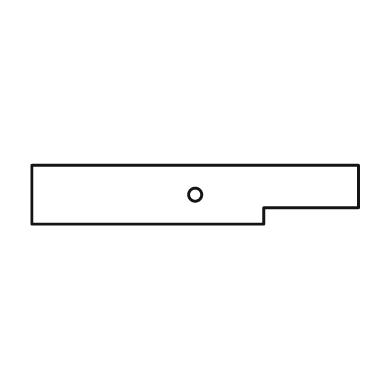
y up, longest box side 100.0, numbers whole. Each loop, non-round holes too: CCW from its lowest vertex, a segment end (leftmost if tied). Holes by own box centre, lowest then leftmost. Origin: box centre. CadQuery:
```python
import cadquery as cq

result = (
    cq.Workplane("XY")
    .moveTo(-50.0, -9.0)
    .lineTo(21.0, -9.0)
    .lineTo(21.0, -4.0)
    .lineTo(50.0, -4.0)
    .lineTo(50.0, 9.0)
    .lineTo(-50.0, 9.0)
    .close()
    .moveTo(0.0, 0.0)
    .circle(2.0)
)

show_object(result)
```